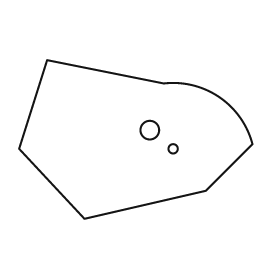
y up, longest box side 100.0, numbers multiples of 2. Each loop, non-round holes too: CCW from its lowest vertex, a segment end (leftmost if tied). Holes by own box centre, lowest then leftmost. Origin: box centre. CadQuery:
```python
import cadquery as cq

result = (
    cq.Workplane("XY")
    .moveTo(-22.0, -34.0)
    .lineTo(30.0, -22.0)
    .lineTo(50.0, -2.0)
    .threePointArc((36.0, 18.0), (12.0, 24.0))
    .lineTo(-38.0, 34.0)
    .lineTo(-50.0, -4.0)
    .close()
    .moveTo(16.0, -4.0)
    .circle(2.0)
    .moveTo(6.0, 4.0)
    .circle(4.0)
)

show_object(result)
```